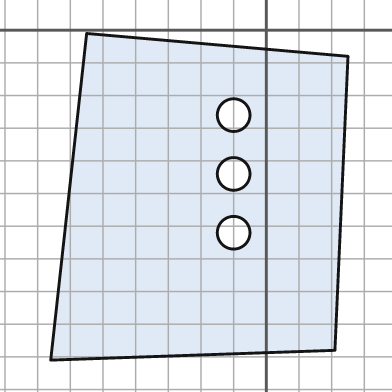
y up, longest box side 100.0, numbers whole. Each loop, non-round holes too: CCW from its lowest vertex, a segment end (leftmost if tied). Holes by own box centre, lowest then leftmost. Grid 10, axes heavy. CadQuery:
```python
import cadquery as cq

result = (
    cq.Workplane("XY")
    .moveTo(-66.0, -101.0)
    .lineTo(21.0, -98.0)
    .lineTo(25.0, -8.0)
    .lineTo(-55.0, -1.0)
    .close()
    .moveTo(-10.0, -62.0)
    .circle(5.0)
    .moveTo(-10.0, -44.0)
    .circle(5.0)
    .moveTo(-10.0, -26.0)
    .circle(5.0)
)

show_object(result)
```